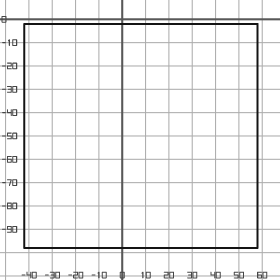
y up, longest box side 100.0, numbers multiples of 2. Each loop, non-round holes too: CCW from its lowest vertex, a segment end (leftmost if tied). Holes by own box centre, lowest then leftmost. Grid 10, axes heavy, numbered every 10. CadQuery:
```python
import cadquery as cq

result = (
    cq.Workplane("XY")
    .moveTo(-42.0, -98.0)
    .lineTo(58.0, -98.0)
    .lineTo(58.0, -2.0)
    .lineTo(-42.0, -2.0)
    .close()
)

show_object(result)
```